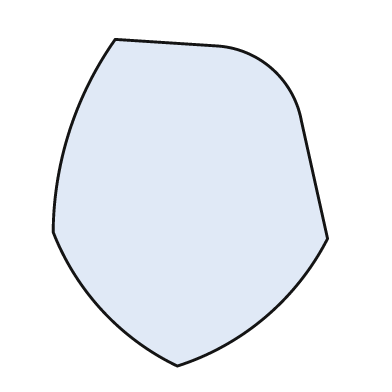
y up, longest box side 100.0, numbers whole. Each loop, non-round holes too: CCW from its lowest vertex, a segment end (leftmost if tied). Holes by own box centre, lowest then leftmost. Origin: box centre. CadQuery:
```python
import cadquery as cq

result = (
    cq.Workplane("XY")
    .moveTo(-4.0, -50.0)
    .threePointArc((23.0, -35.0), (42.0, -11.0))
    .lineTo(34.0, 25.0)
    .threePointArc((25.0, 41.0), (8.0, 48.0))
    .lineTo(-23.0, 50.0)
    .threePointArc((-37.0, 22.0), (-42.0, -9.0))
    .threePointArc((-27.0, -33.0), (-4.0, -50.0))
    .close()
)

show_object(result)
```